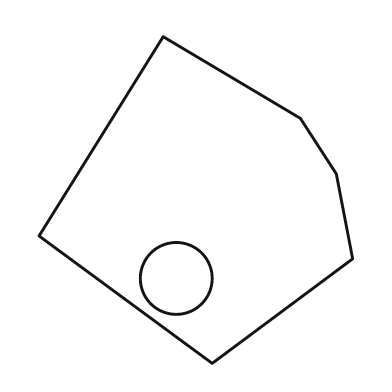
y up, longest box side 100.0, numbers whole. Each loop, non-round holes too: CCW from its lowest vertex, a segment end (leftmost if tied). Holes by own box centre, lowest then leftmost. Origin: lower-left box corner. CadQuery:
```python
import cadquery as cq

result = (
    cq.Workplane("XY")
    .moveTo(53.0, 0.0)
    .lineTo(96.0, 32.0)
    .lineTo(91.0, 58.0)
    .lineTo(80.0, 75.0)
    .lineTo(38.0, 100.0)
    .lineTo(0.0, 39.0)
    .close()
    .moveTo(42.0, 26.0)
    .circle(11.0)
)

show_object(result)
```